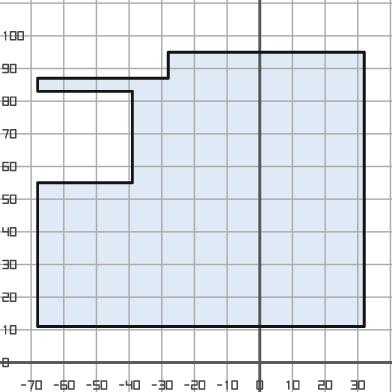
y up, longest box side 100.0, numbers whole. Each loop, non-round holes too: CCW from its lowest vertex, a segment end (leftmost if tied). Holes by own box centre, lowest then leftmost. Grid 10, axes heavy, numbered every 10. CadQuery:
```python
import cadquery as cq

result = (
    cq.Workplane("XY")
    .moveTo(-68.0, 11.0)
    .lineTo(32.0, 11.0)
    .lineTo(32.0, 95.0)
    .lineTo(-28.0, 95.0)
    .lineTo(-28.0, 87.0)
    .lineTo(-68.0, 87.0)
    .lineTo(-68.0, 83.0)
    .lineTo(-39.0, 83.0)
    .lineTo(-39.0, 55.0)
    .lineTo(-68.0, 55.0)
    .close()
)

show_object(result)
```